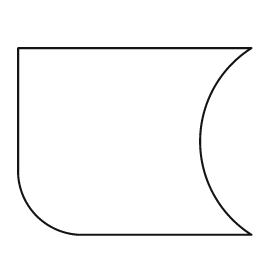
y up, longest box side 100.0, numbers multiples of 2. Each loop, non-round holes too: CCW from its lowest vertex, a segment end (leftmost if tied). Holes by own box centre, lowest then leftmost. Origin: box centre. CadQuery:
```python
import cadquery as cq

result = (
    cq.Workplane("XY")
    .moveTo(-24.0, -40.0)
    .lineTo(50.0, -40.0)
    .threePointArc((28.0, 0.0), (50.0, 40.0))
    .lineTo(-50.0, 40.0)
    .lineTo(-50.0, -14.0)
    .threePointArc((-42.0, -32.0), (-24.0, -40.0))
    .close()
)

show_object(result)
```